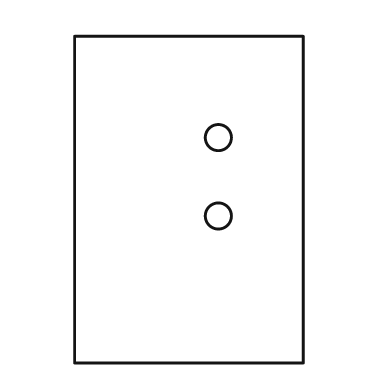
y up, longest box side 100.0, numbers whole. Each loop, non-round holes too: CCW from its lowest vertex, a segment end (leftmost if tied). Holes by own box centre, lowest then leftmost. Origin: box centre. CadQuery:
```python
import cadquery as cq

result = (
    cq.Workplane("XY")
    .moveTo(-35.0, -50.0)
    .lineTo(35.0, -50.0)
    .lineTo(35.0, 50.0)
    .lineTo(-35.0, 50.0)
    .close()
    .moveTo(9.0, -5.0)
    .circle(4.0)
    .moveTo(9.0, 19.0)
    .circle(4.0)
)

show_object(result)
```